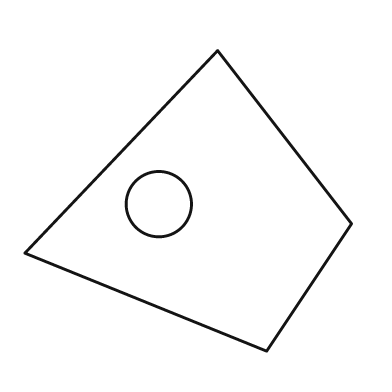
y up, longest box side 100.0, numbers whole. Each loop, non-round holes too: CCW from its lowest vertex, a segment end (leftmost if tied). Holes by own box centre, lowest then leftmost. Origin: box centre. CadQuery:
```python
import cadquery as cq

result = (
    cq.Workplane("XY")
    .moveTo(24.0, -46.0)
    .lineTo(50.0, -7.0)
    .lineTo(9.0, 46.0)
    .lineTo(-50.0, -16.0)
    .close()
    .moveTo(-9.0, -1.0)
    .circle(10.0)
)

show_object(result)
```